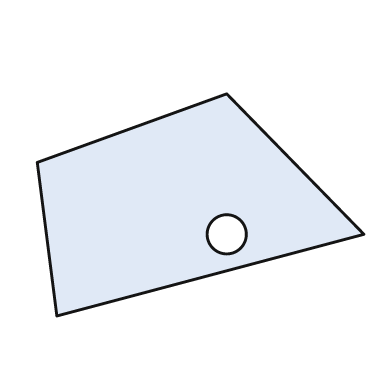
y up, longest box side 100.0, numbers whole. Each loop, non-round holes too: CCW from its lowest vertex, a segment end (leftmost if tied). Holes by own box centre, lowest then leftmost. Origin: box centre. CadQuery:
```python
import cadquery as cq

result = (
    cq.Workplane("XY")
    .moveTo(-44.0, -34.0)
    .lineTo(50.0, -9.0)
    .lineTo(8.0, 34.0)
    .lineTo(-50.0, 13.0)
    .close()
    .moveTo(8.0, -9.0)
    .circle(6.0)
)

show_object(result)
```